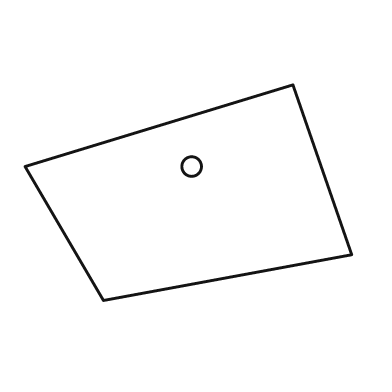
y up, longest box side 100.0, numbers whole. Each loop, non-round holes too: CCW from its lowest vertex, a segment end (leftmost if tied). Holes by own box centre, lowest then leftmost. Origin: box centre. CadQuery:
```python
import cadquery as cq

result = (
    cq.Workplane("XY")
    .moveTo(-26.0, -33.0)
    .lineTo(50.0, -19.0)
    .lineTo(32.0, 33.0)
    .lineTo(-50.0, 8.0)
    .close()
    .moveTo(1.0, 8.0)
    .circle(3.0)
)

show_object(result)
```